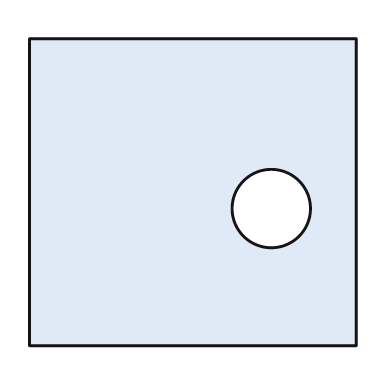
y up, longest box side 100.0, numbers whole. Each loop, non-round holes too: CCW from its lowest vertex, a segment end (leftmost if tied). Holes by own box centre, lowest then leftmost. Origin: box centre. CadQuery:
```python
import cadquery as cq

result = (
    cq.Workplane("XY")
    .moveTo(-50.0, -47.0)
    .lineTo(50.0, -47.0)
    .lineTo(50.0, 47.0)
    .lineTo(-50.0, 47.0)
    .close()
    .moveTo(24.0, -5.0)
    .circle(12.0)
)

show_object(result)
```